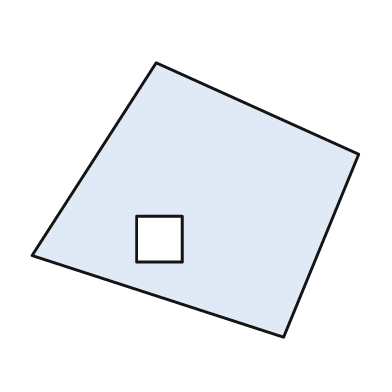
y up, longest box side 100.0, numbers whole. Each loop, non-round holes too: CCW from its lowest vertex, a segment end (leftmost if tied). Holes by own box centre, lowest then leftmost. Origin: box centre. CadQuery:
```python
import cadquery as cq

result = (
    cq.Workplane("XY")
    .moveTo(27.0, -42.0)
    .lineTo(50.0, 14.0)
    .lineTo(-12.0, 42.0)
    .lineTo(-50.0, -17.0)
    .close()
    .moveTo(-18.0, -19.0)
    .lineTo(-4.0, -19.0)
    .lineTo(-4.0, -5.0)
    .lineTo(-18.0, -5.0)
    .close()
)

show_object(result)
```